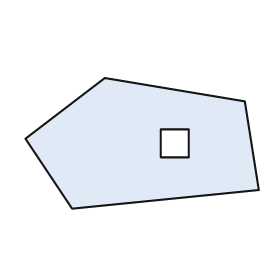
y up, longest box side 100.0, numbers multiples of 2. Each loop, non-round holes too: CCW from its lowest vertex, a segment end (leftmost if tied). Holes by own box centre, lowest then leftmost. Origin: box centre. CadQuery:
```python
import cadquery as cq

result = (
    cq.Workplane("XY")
    .moveTo(-30.0, -28.0)
    .lineTo(50.0, -20.0)
    .lineTo(44.0, 18.0)
    .lineTo(-16.0, 28.0)
    .lineTo(-50.0, 2.0)
    .close()
    .moveTo(8.0, -6.0)
    .lineTo(20.0, -6.0)
    .lineTo(20.0, 6.0)
    .lineTo(8.0, 6.0)
    .close()
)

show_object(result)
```